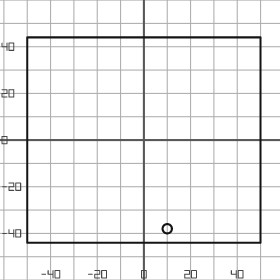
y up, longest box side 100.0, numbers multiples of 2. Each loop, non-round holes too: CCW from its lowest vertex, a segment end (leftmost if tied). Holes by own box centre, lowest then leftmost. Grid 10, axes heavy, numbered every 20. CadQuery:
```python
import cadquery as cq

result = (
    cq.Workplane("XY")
    .moveTo(-50.0, -44.0)
    .lineTo(50.0, -44.0)
    .lineTo(50.0, 44.0)
    .lineTo(-50.0, 44.0)
    .close()
    .moveTo(10.0, -38.0)
    .circle(2.0)
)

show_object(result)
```